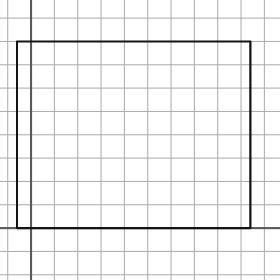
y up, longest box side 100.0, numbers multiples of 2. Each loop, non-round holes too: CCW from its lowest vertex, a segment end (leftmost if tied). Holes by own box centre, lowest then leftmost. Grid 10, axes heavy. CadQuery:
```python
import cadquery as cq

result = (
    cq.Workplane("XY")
    .moveTo(-6.0, 0.0)
    .lineTo(94.0, 0.0)
    .lineTo(94.0, 80.0)
    .lineTo(-6.0, 80.0)
    .close()
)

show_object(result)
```